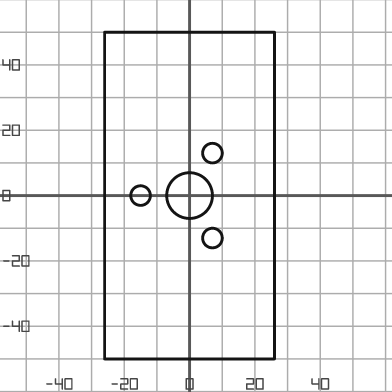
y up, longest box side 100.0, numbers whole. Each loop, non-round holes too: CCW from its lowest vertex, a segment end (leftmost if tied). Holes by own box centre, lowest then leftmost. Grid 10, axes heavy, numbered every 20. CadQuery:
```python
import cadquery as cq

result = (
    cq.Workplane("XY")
    .moveTo(-26.0, -50.0)
    .lineTo(26.0, -50.0)
    .lineTo(26.0, 50.0)
    .lineTo(-26.0, 50.0)
    .close()
    .moveTo(7.0, -13.0)
    .circle(3.0)
    .moveTo(-15.0, 0.0)
    .circle(3.0)
    .moveTo(0.0, 0.0)
    .circle(7.0)
    .moveTo(7.0, 13.0)
    .circle(3.0)
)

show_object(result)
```